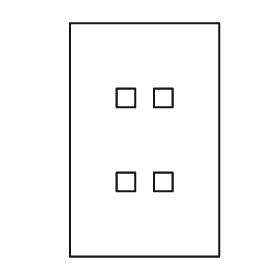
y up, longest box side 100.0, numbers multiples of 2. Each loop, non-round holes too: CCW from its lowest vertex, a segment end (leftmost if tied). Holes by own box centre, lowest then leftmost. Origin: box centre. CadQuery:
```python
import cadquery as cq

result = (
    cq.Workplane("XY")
    .moveTo(-32.0, -50.0)
    .lineTo(32.0, -50.0)
    .lineTo(32.0, 50.0)
    .lineTo(-32.0, 50.0)
    .close()
    .moveTo(-12.0, -22.0)
    .lineTo(-4.0, -22.0)
    .lineTo(-4.0, -14.0)
    .lineTo(-12.0, -14.0)
    .close()
    .moveTo(4.0, -22.0)
    .lineTo(12.0, -22.0)
    .lineTo(12.0, -14.0)
    .lineTo(4.0, -14.0)
    .close()
    .moveTo(-12.0, 14.0)
    .lineTo(-4.0, 14.0)
    .lineTo(-4.0, 22.0)
    .lineTo(-12.0, 22.0)
    .close()
    .moveTo(4.0, 14.0)
    .lineTo(12.0, 14.0)
    .lineTo(12.0, 22.0)
    .lineTo(4.0, 22.0)
    .close()
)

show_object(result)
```